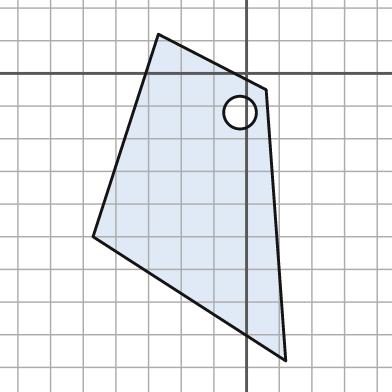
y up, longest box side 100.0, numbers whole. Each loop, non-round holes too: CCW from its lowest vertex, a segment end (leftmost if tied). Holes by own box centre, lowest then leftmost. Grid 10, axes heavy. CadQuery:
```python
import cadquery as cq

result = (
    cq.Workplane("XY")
    .moveTo(12.0, -88.0)
    .lineTo(6.0, -5.0)
    .lineTo(-27.0, 12.0)
    .lineTo(-47.0, -50.0)
    .close()
    .moveTo(-2.0, -12.0)
    .circle(5.0)
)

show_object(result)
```